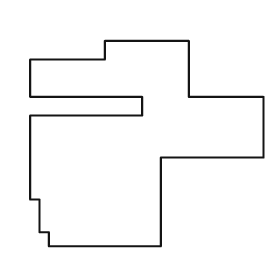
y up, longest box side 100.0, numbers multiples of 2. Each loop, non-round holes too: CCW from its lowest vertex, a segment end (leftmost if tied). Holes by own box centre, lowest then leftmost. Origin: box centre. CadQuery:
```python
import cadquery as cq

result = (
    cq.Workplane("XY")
    .moveTo(-42.0, -44.0)
    .lineTo(6.0, -44.0)
    .lineTo(6.0, -6.0)
    .lineTo(50.0, -6.0)
    .lineTo(50.0, 20.0)
    .lineTo(18.0, 20.0)
    .lineTo(18.0, 44.0)
    .lineTo(-18.0, 44.0)
    .lineTo(-18.0, 36.0)
    .lineTo(-50.0, 36.0)
    .lineTo(-50.0, 20.0)
    .lineTo(-2.0, 20.0)
    .lineTo(-2.0, 12.0)
    .lineTo(-50.0, 12.0)
    .lineTo(-50.0, -24.0)
    .lineTo(-46.0, -24.0)
    .lineTo(-46.0, -38.0)
    .lineTo(-42.0, -38.0)
    .close()
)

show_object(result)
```